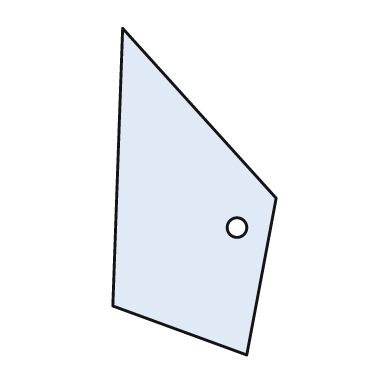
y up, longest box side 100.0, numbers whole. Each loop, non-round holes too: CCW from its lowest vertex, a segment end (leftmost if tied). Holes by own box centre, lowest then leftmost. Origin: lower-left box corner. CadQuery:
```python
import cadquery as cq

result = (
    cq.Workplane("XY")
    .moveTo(41.0, 0.0)
    .lineTo(50.0, 48.0)
    .lineTo(3.0, 100.0)
    .lineTo(0.0, 15.0)
    .close()
    .moveTo(38.0, 39.0)
    .circle(3.0)
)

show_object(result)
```